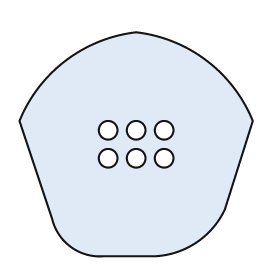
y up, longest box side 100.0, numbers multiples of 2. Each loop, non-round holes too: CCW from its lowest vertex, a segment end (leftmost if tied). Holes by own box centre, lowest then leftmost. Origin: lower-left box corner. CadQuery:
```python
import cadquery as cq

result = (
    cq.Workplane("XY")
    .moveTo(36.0, 0.0)
    .lineTo(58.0, 0.0)
    .threePointArc((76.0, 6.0), (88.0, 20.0))
    .lineTo(100.0, 58.0)
    .threePointArc((80.0, 84.0), (50.0, 96.0))
    .threePointArc((20.0, 84.0), (0.0, 58.0))
    .lineTo(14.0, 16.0)
    .threePointArc((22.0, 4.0), (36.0, 0.0))
    .close()
    .moveTo(38.0, 42.0)
    .circle(4.0)
    .moveTo(50.0, 42.0)
    .circle(4.0)
    .moveTo(62.0, 42.0)
    .circle(4.0)
    .moveTo(38.0, 54.0)
    .circle(4.0)
    .moveTo(50.0, 54.0)
    .circle(4.0)
    .moveTo(62.0, 54.0)
    .circle(4.0)
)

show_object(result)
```